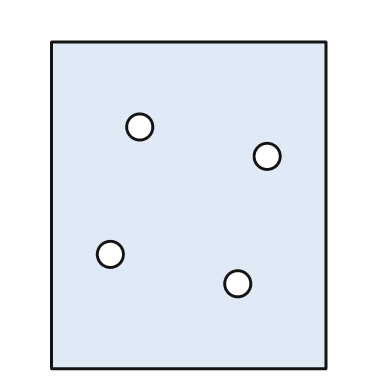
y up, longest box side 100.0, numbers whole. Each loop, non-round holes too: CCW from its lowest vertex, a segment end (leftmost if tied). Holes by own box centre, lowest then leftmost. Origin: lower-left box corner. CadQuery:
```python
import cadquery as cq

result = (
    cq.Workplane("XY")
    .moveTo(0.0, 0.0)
    .lineTo(84.0, 0.0)
    .lineTo(84.0, 100.0)
    .lineTo(0.0, 100.0)
    .close()
    .moveTo(57.0, 26.0)
    .circle(4.0)
    .moveTo(18.0, 35.0)
    .circle(4.0)
    .moveTo(66.0, 65.0)
    .circle(4.0)
    .moveTo(27.0, 74.0)
    .circle(4.0)
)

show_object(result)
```